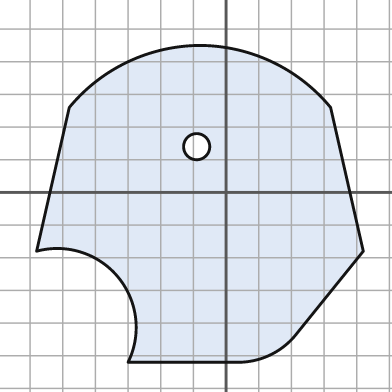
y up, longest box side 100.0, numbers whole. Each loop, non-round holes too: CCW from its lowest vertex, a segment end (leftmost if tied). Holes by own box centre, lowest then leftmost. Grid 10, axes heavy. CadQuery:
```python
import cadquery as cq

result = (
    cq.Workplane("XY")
    .moveTo(-30.0, -52.0)
    .lineTo(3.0, -52.0)
    .threePointArc((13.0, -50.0), (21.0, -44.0))
    .lineTo(42.0, -18.0)
    .lineTo(32.0, 26.0)
    .threePointArc((14.0, 40.0), (-8.0, 45.0))
    .threePointArc((-30.0, 40.0), (-48.0, 26.0))
    .lineTo(-58.0, -18.0)
    .threePointArc((-33.0, -26.0), (-30.0, -52.0))
    .close()
    .moveTo(-9.0, 14.0)
    .circle(4.0)
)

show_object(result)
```